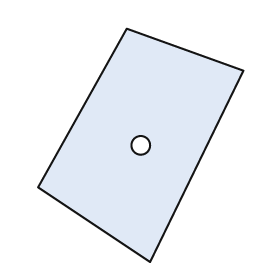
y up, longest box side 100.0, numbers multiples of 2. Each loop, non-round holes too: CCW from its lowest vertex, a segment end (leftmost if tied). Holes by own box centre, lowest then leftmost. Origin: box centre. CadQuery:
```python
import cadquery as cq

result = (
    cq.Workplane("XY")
    .moveTo(4.0, -50.0)
    .lineTo(44.0, 32.0)
    .lineTo(-6.0, 50.0)
    .lineTo(-44.0, -18.0)
    .close()
    .moveTo(0.0, 0.0)
    .circle(4.0)
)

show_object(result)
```